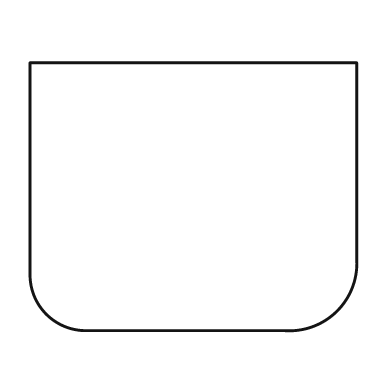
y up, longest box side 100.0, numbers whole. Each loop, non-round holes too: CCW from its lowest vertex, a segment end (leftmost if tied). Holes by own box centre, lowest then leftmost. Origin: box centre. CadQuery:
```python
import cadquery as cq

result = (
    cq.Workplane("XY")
    .moveTo(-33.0, -41.0)
    .lineTo(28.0, -41.0)
    .threePointArc((44.0, -35.0), (50.0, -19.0))
    .lineTo(50.0, 41.0)
    .lineTo(-50.0, 41.0)
    .lineTo(-50.0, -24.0)
    .threePointArc((-45.0, -36.0), (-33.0, -41.0))
    .close()
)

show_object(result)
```